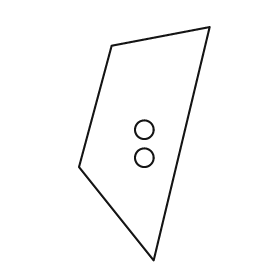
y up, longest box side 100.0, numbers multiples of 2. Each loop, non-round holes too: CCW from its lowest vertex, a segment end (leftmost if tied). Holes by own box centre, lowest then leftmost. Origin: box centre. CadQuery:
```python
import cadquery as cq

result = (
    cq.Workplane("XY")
    .moveTo(4.0, -50.0)
    .lineTo(28.0, 50.0)
    .lineTo(-14.0, 42.0)
    .lineTo(-28.0, -10.0)
    .close()
    .moveTo(0.0, -6.0)
    .circle(4.0)
    .moveTo(0.0, 6.0)
    .circle(4.0)
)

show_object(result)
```